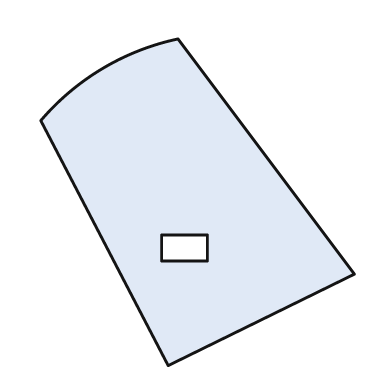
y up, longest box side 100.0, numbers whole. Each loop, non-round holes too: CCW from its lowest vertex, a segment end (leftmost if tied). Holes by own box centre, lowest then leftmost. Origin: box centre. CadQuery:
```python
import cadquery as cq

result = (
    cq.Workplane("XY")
    .moveTo(-9.0, -50.0)
    .lineTo(48.0, -22.0)
    .lineTo(-6.0, 50.0)
    .threePointArc((-29.0, 41.0), (-48.0, 25.0))
    .close()
    .moveTo(-11.0, -18.0)
    .lineTo(3.0, -18.0)
    .lineTo(3.0, -10.0)
    .lineTo(-11.0, -10.0)
    .close()
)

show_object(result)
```